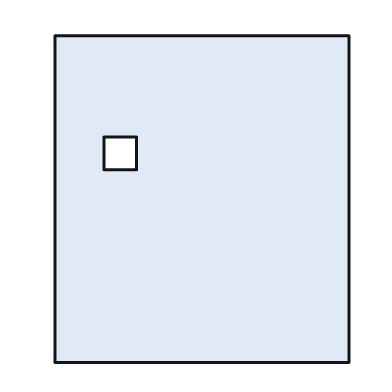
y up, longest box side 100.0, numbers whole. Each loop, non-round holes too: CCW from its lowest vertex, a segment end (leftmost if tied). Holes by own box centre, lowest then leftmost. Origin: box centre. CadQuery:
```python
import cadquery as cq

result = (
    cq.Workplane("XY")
    .moveTo(-45.0, -50.0)
    .lineTo(45.0, -50.0)
    .lineTo(45.0, 50.0)
    .lineTo(-45.0, 50.0)
    .close()
    .moveTo(-30.0, 9.0)
    .lineTo(-20.0, 9.0)
    .lineTo(-20.0, 19.0)
    .lineTo(-30.0, 19.0)
    .close()
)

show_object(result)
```